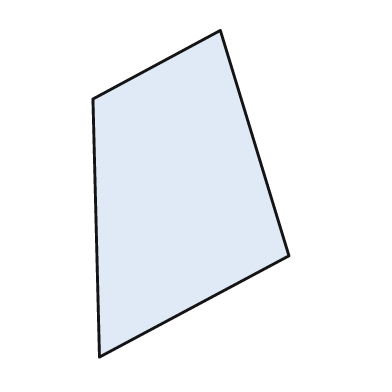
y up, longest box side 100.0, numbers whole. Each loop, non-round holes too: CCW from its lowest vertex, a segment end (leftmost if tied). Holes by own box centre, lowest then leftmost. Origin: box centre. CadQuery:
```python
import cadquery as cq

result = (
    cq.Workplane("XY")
    .moveTo(-28.0, -50.0)
    .lineTo(30.0, -19.0)
    .lineTo(9.0, 50.0)
    .lineTo(-30.0, 29.0)
    .close()
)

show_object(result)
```